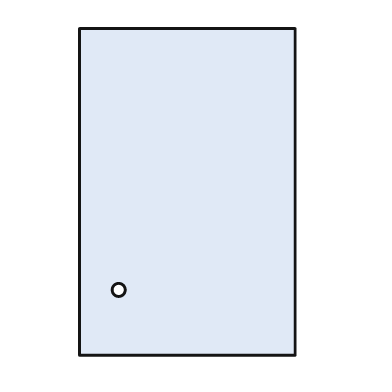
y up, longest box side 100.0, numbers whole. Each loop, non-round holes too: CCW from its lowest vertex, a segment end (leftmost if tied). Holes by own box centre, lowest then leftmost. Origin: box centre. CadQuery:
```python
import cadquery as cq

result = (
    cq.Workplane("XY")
    .moveTo(-33.0, -50.0)
    .lineTo(33.0, -50.0)
    .lineTo(33.0, 50.0)
    .lineTo(-33.0, 50.0)
    .close()
    .moveTo(-21.0, -30.0)
    .circle(2.0)
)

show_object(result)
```